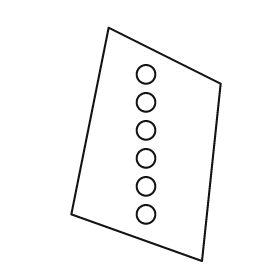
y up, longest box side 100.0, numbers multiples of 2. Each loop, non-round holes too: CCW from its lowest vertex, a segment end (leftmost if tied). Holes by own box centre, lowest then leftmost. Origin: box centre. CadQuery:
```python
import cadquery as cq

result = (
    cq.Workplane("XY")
    .moveTo(24.0, -50.0)
    .lineTo(32.0, 26.0)
    .lineTo(-16.0, 50.0)
    .lineTo(-32.0, -30.0)
    .close()
    .moveTo(0.0, -30.0)
    .circle(4.0)
    .moveTo(0.0, -18.0)
    .circle(4.0)
    .moveTo(0.0, -6.0)
    .circle(4.0)
    .moveTo(0.0, 6.0)
    .circle(4.0)
    .moveTo(0.0, 18.0)
    .circle(4.0)
    .moveTo(0.0, 30.0)
    .circle(4.0)
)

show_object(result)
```